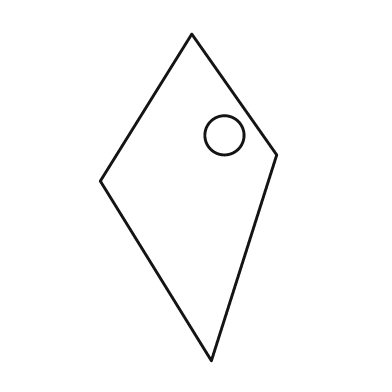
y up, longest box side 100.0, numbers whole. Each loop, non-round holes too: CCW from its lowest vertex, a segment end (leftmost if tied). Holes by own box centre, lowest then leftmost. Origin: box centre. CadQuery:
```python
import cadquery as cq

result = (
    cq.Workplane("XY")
    .moveTo(7.0, -50.0)
    .lineTo(27.0, 13.0)
    .lineTo(1.0, 50.0)
    .lineTo(-27.0, 5.0)
    .close()
    .moveTo(11.0, 19.0)
    .circle(6.0)
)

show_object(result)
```